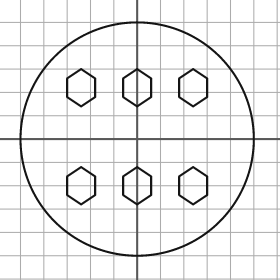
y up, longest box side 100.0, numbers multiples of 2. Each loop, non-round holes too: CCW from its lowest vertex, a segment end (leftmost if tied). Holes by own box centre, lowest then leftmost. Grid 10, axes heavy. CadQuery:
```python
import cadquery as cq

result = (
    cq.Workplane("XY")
    .moveTo(0.0, 0.0)
    .circle(50.0)
    .moveTo(-24.0, -28.0)
    .lineTo(-18.0, -24.0)
    .lineTo(-18.0, -16.0)
    .lineTo(-24.0, -12.0)
    .lineTo(-30.0, -16.0)
    .lineTo(-30.0, -24.0)
    .close()
    .moveTo(0.0, -28.0)
    .lineTo(6.0, -24.0)
    .lineTo(6.0, -16.0)
    .lineTo(0.0, -12.0)
    .lineTo(-6.0, -16.0)
    .lineTo(-6.0, -24.0)
    .close()
    .moveTo(24.0, -28.0)
    .lineTo(30.0, -24.0)
    .lineTo(30.0, -16.0)
    .lineTo(24.0, -12.0)
    .lineTo(18.0, -16.0)
    .lineTo(18.0, -24.0)
    .close()
    .moveTo(-24.0, 14.0)
    .lineTo(-18.0, 18.0)
    .lineTo(-18.0, 26.0)
    .lineTo(-24.0, 30.0)
    .lineTo(-30.0, 26.0)
    .lineTo(-30.0, 18.0)
    .close()
    .moveTo(0.0, 14.0)
    .lineTo(6.0, 18.0)
    .lineTo(6.0, 26.0)
    .lineTo(0.0, 30.0)
    .lineTo(-6.0, 26.0)
    .lineTo(-6.0, 18.0)
    .close()
    .moveTo(24.0, 14.0)
    .lineTo(30.0, 18.0)
    .lineTo(30.0, 26.0)
    .lineTo(24.0, 30.0)
    .lineTo(18.0, 26.0)
    .lineTo(18.0, 18.0)
    .close()
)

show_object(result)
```